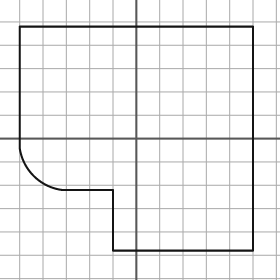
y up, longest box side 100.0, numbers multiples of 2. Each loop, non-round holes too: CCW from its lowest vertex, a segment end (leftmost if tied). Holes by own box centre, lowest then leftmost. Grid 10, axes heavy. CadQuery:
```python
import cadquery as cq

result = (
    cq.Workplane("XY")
    .moveTo(-10.0, -48.0)
    .lineTo(50.0, -48.0)
    .lineTo(50.0, 48.0)
    .lineTo(-50.0, 48.0)
    .lineTo(-50.0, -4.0)
    .threePointArc((-44.0, -16.0), (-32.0, -22.0))
    .lineTo(-10.0, -22.0)
    .close()
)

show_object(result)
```